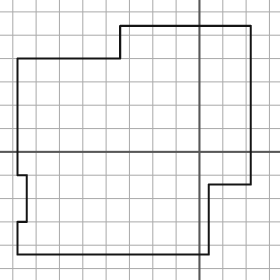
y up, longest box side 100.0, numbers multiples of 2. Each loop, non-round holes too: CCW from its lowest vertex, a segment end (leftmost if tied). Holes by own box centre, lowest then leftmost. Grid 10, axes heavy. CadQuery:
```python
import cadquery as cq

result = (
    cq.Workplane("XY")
    .moveTo(-78.0, -44.0)
    .lineTo(4.0, -44.0)
    .lineTo(4.0, -14.0)
    .lineTo(22.0, -14.0)
    .lineTo(22.0, 54.0)
    .lineTo(-34.0, 54.0)
    .lineTo(-34.0, 40.0)
    .lineTo(-78.0, 40.0)
    .lineTo(-78.0, -10.0)
    .lineTo(-74.0, -10.0)
    .lineTo(-74.0, -30.0)
    .lineTo(-78.0, -30.0)
    .close()
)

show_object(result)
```